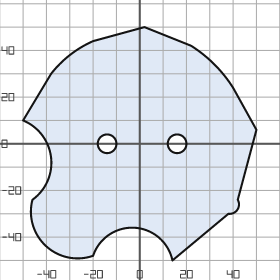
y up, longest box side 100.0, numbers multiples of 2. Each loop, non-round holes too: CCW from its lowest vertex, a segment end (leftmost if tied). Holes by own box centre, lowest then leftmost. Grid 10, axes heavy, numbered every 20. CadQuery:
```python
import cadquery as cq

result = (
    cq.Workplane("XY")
    .moveTo(14.0, -50.0)
    .lineTo(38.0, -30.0)
    .threePointArc((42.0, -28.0), (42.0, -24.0))
    .lineTo(50.0, 6.0)
    .lineTo(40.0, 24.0)
    .threePointArc((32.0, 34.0), (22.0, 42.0))
    .lineTo(2.0, 50.0)
    .lineTo(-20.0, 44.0)
    .threePointArc((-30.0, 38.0), (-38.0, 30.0))
    .lineTo(-50.0, 10.0)
    .threePointArc((-38.0, -6.0), (-46.0, -24.0))
    .threePointArc((-40.0, -44.0), (-20.0, -48.0))
    .threePointArc((-2.0, -36.0), (14.0, -50.0))
    .close()
    .moveTo(-14.0, 0.0)
    .circle(4.0)
    .moveTo(16.0, 0.0)
    .circle(4.0)
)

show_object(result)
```